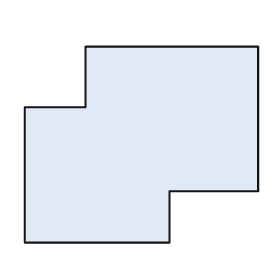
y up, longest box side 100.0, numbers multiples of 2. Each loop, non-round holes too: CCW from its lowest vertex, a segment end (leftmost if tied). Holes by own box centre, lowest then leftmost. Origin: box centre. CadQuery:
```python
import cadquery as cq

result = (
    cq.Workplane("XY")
    .moveTo(-50.0, -42.0)
    .lineTo(12.0, -42.0)
    .lineTo(12.0, -20.0)
    .lineTo(50.0, -20.0)
    .lineTo(50.0, 42.0)
    .lineTo(-24.0, 42.0)
    .lineTo(-24.0, 16.0)
    .lineTo(-50.0, 16.0)
    .close()
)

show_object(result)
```